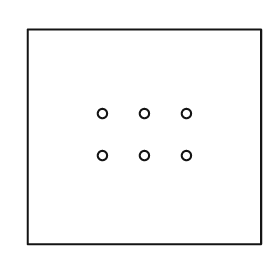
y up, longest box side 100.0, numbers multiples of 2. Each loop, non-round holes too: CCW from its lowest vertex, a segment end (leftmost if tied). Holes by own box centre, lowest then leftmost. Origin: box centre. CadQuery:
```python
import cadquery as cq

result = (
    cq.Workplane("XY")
    .moveTo(-50.0, -46.0)
    .lineTo(50.0, -46.0)
    .lineTo(50.0, 46.0)
    .lineTo(-50.0, 46.0)
    .close()
    .moveTo(-18.0, -8.0)
    .circle(2.0)
    .moveTo(0.0, -8.0)
    .circle(2.0)
    .moveTo(18.0, -8.0)
    .circle(2.0)
    .moveTo(-18.0, 10.0)
    .circle(2.0)
    .moveTo(0.0, 10.0)
    .circle(2.0)
    .moveTo(18.0, 10.0)
    .circle(2.0)
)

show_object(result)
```